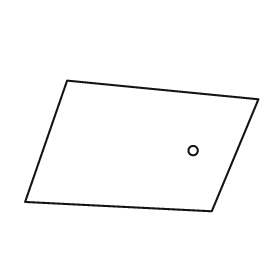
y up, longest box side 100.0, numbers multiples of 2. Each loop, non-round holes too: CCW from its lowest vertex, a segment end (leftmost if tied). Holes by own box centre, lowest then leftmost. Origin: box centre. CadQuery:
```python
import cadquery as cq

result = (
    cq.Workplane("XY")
    .moveTo(30.0, -28.0)
    .lineTo(50.0, 20.0)
    .lineTo(-32.0, 28.0)
    .lineTo(-50.0, -24.0)
    .close()
    .moveTo(22.0, -2.0)
    .circle(2.0)
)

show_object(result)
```